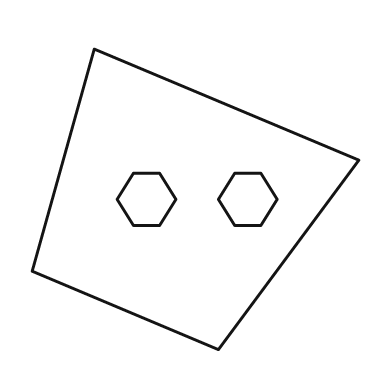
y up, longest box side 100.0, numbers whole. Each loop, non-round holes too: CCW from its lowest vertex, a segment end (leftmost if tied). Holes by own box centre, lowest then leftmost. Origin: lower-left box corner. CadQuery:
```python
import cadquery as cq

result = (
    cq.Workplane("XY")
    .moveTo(57.0, 0.0)
    .lineTo(100.0, 58.0)
    .lineTo(19.0, 92.0)
    .lineTo(0.0, 24.0)
    .close()
    .moveTo(31.0, 38.0)
    .lineTo(39.0, 38.0)
    .lineTo(44.0, 46.0)
    .lineTo(39.0, 54.0)
    .lineTo(31.0, 54.0)
    .lineTo(26.0, 46.0)
    .close()
    .moveTo(62.0, 38.0)
    .lineTo(70.0, 38.0)
    .lineTo(75.0, 46.0)
    .lineTo(70.0, 54.0)
    .lineTo(62.0, 54.0)
    .lineTo(57.0, 46.0)
    .close()
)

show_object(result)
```